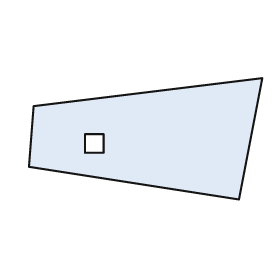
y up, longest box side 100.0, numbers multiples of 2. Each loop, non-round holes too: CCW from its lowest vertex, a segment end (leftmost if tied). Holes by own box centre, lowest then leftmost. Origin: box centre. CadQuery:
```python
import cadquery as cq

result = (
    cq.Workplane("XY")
    .moveTo(40.0, -26.0)
    .lineTo(50.0, 26.0)
    .lineTo(-48.0, 14.0)
    .lineTo(-50.0, -12.0)
    .close()
    .moveTo(-26.0, -6.0)
    .lineTo(-18.0, -6.0)
    .lineTo(-18.0, 2.0)
    .lineTo(-26.0, 2.0)
    .close()
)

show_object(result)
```